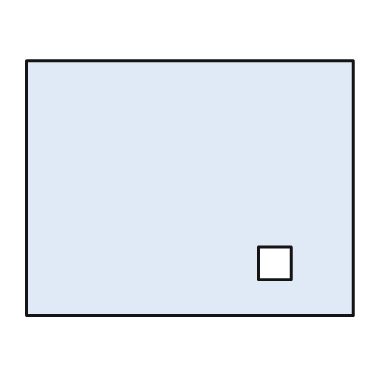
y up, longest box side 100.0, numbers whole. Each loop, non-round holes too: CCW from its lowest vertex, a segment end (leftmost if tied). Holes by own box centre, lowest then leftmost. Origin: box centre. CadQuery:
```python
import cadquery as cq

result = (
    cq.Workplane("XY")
    .moveTo(-50.0, -39.0)
    .lineTo(50.0, -39.0)
    .lineTo(50.0, 39.0)
    .lineTo(-50.0, 39.0)
    .close()
    .moveTo(21.0, -28.0)
    .lineTo(31.0, -28.0)
    .lineTo(31.0, -18.0)
    .lineTo(21.0, -18.0)
    .close()
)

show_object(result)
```